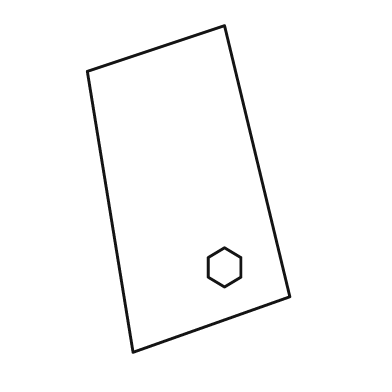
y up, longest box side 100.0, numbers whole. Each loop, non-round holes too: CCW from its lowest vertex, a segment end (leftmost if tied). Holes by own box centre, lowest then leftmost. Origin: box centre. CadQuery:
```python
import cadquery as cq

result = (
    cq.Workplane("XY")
    .moveTo(-17.0, -50.0)
    .lineTo(31.0, -33.0)
    .lineTo(11.0, 50.0)
    .lineTo(-31.0, 36.0)
    .close()
    .moveTo(11.0, -30.0)
    .lineTo(16.0, -27.0)
    .lineTo(16.0, -21.0)
    .lineTo(11.0, -18.0)
    .lineTo(6.0, -21.0)
    .lineTo(6.0, -27.0)
    .close()
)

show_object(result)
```